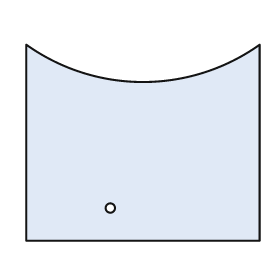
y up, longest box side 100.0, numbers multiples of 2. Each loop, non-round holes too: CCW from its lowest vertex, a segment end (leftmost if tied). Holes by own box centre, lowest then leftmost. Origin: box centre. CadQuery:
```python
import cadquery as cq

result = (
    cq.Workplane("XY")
    .moveTo(-50.0, -42.0)
    .lineTo(50.0, -42.0)
    .lineTo(50.0, 42.0)
    .threePointArc((0.0, 26.0), (-50.0, 42.0))
    .close()
    .moveTo(-14.0, -28.0)
    .circle(2.0)
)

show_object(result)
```